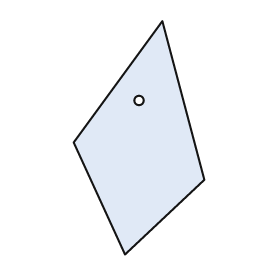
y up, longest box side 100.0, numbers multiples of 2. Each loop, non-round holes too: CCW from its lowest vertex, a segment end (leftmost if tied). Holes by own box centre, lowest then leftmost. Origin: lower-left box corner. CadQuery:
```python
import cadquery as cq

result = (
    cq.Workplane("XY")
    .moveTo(22.0, 0.0)
    .lineTo(56.0, 32.0)
    .lineTo(38.0, 100.0)
    .lineTo(0.0, 48.0)
    .close()
    .moveTo(28.0, 66.0)
    .circle(2.0)
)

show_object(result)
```